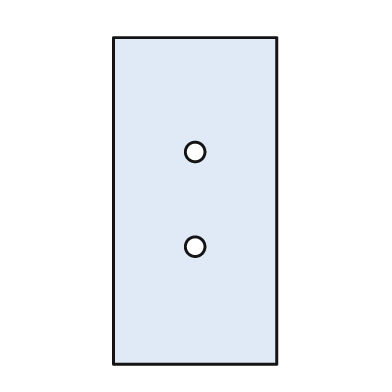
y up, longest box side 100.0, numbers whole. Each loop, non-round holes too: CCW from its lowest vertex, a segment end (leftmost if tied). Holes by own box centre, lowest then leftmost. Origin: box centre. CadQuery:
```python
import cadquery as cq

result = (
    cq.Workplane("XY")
    .moveTo(-25.0, -50.0)
    .lineTo(25.0, -50.0)
    .lineTo(25.0, 50.0)
    .lineTo(-25.0, 50.0)
    .close()
    .moveTo(0.0, -14.0)
    .circle(3.0)
    .moveTo(0.0, 15.0)
    .circle(3.0)
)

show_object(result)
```